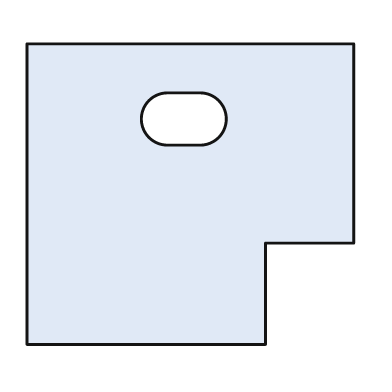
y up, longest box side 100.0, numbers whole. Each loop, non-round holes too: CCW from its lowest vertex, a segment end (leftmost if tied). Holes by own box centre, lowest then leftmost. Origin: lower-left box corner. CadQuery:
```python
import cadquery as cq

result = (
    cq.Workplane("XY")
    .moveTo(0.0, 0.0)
    .lineTo(73.0, 0.0)
    .lineTo(73.0, 31.0)
    .lineTo(100.0, 31.0)
    .lineTo(100.0, 92.0)
    .lineTo(0.0, 92.0)
    .close()
    .moveTo(43.0, 61.0)
    .lineTo(53.0, 61.0)
    .threePointArc((61.0, 69.0), (53.0, 77.0))
    .lineTo(43.0, 77.0)
    .threePointArc((35.0, 69.0), (43.0, 61.0))
    .close()
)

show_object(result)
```